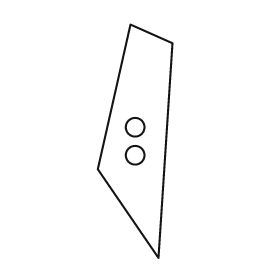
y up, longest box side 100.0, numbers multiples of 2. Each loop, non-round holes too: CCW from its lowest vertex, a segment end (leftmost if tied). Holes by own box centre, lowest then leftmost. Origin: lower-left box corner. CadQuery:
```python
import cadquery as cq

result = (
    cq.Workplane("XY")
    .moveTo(26.0, 0.0)
    .lineTo(32.0, 92.0)
    .lineTo(14.0, 100.0)
    .lineTo(0.0, 38.0)
    .close()
    .moveTo(16.0, 44.0)
    .circle(4.0)
    .moveTo(16.0, 56.0)
    .circle(4.0)
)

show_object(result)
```